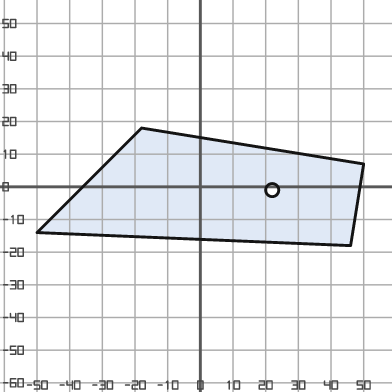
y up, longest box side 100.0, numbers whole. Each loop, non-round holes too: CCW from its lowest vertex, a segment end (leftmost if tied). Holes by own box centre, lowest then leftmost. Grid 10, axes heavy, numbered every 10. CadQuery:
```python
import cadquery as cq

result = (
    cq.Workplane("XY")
    .moveTo(46.0, -18.0)
    .lineTo(50.0, 7.0)
    .lineTo(-18.0, 18.0)
    .lineTo(-50.0, -14.0)
    .close()
    .moveTo(22.0, -1.0)
    .circle(2.0)
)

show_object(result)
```